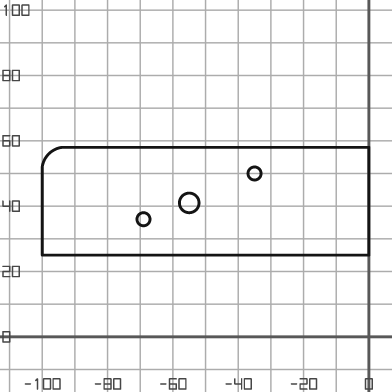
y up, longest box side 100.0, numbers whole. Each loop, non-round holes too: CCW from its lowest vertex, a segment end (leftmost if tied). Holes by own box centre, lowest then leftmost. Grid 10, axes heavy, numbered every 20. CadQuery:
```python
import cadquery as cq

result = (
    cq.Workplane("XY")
    .moveTo(-100.0, 25.0)
    .lineTo(0.0, 25.0)
    .lineTo(0.0, 58.0)
    .lineTo(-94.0, 58.0)
    .threePointArc((-98.0, 56.0), (-100.0, 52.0))
    .close()
    .moveTo(-69.0, 36.0)
    .circle(2.0)
    .moveTo(-55.0, 41.0)
    .circle(3.0)
    .moveTo(-35.0, 50.0)
    .circle(2.0)
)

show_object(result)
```